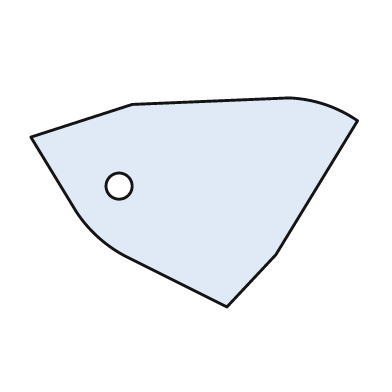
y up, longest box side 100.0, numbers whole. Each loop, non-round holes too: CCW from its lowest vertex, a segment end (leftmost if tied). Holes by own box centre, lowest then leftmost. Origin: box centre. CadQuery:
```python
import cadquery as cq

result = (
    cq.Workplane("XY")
    .moveTo(10.0, -32.0)
    .lineTo(25.0, -16.0)
    .lineTo(50.0, 25.0)
    .threePointArc((40.0, 30.0), (29.0, 32.0))
    .lineTo(-19.0, 30.0)
    .lineTo(-50.0, 20.0)
    .lineTo(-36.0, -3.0)
    .threePointArc((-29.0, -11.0), (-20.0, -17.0))
    .close()
    .moveTo(-23.0, 5.0)
    .circle(4.0)
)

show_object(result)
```